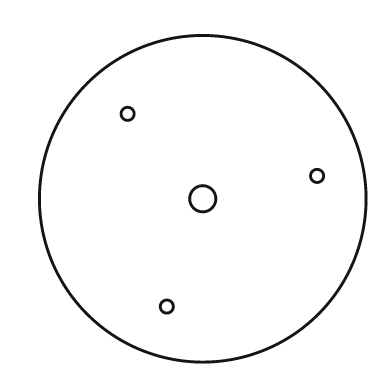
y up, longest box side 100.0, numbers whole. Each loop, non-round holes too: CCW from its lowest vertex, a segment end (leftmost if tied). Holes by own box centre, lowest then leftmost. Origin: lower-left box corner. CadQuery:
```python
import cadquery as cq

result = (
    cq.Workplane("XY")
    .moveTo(50.0, 50.0)
    .circle(50.0)
    .moveTo(39.0, 17.0)
    .circle(2.0)
    .moveTo(50.0, 50.0)
    .circle(4.0)
    .moveTo(85.0, 57.0)
    .circle(2.0)
    .moveTo(27.0, 76.0)
    .circle(2.0)
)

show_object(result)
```